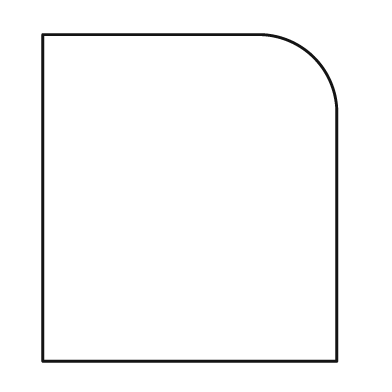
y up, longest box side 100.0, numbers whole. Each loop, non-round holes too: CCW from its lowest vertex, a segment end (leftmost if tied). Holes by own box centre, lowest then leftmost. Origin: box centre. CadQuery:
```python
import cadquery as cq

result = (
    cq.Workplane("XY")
    .moveTo(-45.0, -50.0)
    .lineTo(45.0, -50.0)
    .lineTo(45.0, 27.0)
    .threePointArc((38.0, 43.0), (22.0, 50.0))
    .lineTo(-45.0, 50.0)
    .close()
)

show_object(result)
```